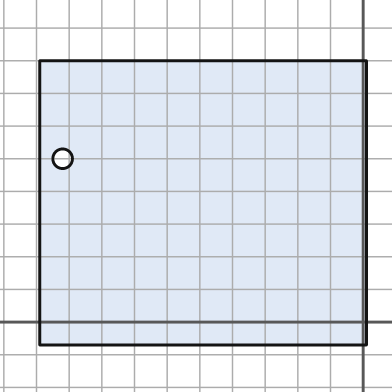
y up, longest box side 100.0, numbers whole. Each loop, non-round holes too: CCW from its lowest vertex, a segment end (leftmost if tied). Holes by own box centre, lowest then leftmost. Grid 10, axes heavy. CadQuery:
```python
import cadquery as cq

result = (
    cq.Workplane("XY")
    .moveTo(-99.0, -7.0)
    .lineTo(1.0, -7.0)
    .lineTo(1.0, 80.0)
    .lineTo(-99.0, 80.0)
    .close()
    .moveTo(-92.0, 50.0)
    .circle(3.0)
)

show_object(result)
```